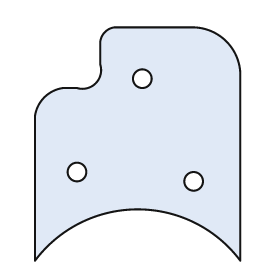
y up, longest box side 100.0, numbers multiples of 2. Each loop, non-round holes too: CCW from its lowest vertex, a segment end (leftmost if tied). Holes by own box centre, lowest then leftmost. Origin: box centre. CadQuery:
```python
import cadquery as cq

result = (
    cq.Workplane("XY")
    .moveTo(-44.0, -50.0)
    .threePointArc((0.0, -28.0), (44.0, -50.0))
    .lineTo(44.0, 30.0)
    .threePointArc((38.0, 44.0), (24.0, 50.0))
    .lineTo(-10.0, 50.0)
    .threePointArc((-14.0, 48.0), (-16.0, 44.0))
    .lineTo(-16.0, 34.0)
    .threePointArc((-18.0, 26.0), (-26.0, 24.0))
    .lineTo(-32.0, 24.0)
    .threePointArc((-40.0, 20.0), (-44.0, 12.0))
    .close()
    .moveTo(24.0, -16.0)
    .circle(4.0)
    .moveTo(-26.0, -12.0)
    .circle(4.0)
    .moveTo(2.0, 28.0)
    .circle(4.0)
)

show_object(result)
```